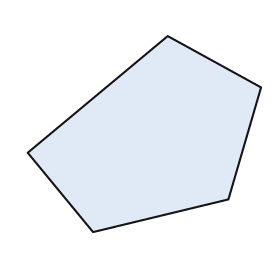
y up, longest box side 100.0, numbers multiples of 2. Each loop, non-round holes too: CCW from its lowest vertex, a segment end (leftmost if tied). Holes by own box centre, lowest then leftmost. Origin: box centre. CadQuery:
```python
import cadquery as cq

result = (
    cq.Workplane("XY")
    .moveTo(-22.0, -42.0)
    .lineTo(36.0, -28.0)
    .lineTo(50.0, 20.0)
    .lineTo(10.0, 42.0)
    .lineTo(-50.0, -8.0)
    .close()
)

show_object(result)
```